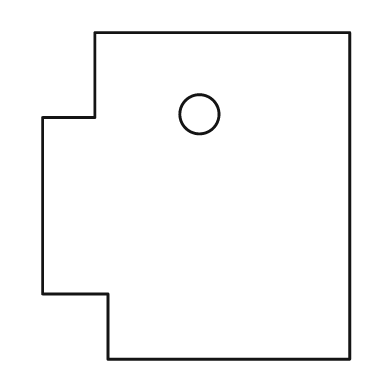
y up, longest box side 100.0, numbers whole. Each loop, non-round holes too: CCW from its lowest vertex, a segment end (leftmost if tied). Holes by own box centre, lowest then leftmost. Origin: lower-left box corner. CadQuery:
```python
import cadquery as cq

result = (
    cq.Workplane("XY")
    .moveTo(20.0, 0.0)
    .lineTo(94.0, 0.0)
    .lineTo(94.0, 100.0)
    .lineTo(16.0, 100.0)
    .lineTo(16.0, 74.0)
    .lineTo(0.0, 74.0)
    .lineTo(0.0, 20.0)
    .lineTo(20.0, 20.0)
    .close()
    .moveTo(48.0, 75.0)
    .circle(6.0)
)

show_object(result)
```